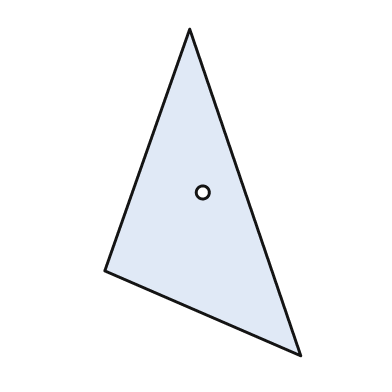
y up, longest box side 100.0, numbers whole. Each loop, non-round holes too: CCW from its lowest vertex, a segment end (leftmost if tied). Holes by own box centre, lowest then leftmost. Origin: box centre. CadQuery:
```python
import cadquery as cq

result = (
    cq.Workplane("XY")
    .moveTo(30.0, -50.0)
    .lineTo(-4.0, 50.0)
    .lineTo(-30.0, -24.0)
    .close()
    .moveTo(0.0, 0.0)
    .circle(2.0)
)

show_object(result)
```